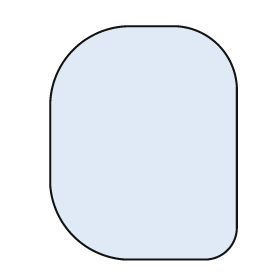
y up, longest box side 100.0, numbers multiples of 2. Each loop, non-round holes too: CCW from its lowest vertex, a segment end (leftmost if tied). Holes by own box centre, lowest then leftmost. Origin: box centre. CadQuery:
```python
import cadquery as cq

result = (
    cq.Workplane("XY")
    .moveTo(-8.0, -50.0)
    .lineTo(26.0, -50.0)
    .threePointArc((36.0, -46.0), (40.0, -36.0))
    .lineTo(40.0, 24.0)
    .threePointArc((32.0, 42.0), (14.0, 50.0))
    .lineTo(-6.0, 50.0)
    .threePointArc((-30.0, 40.0), (-40.0, 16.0))
    .lineTo(-40.0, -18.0)
    .threePointArc((-30.0, -40.0), (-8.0, -50.0))
    .close()
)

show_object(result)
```